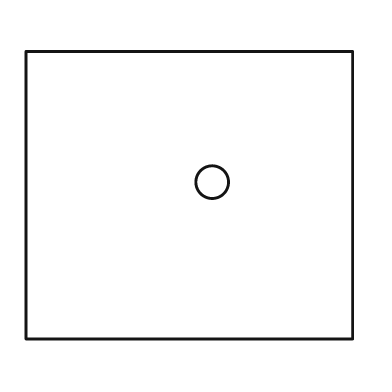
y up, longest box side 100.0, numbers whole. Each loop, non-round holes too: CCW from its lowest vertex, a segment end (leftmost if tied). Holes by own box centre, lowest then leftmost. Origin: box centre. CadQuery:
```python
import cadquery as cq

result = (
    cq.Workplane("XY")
    .moveTo(-50.0, -44.0)
    .lineTo(50.0, -44.0)
    .lineTo(50.0, 44.0)
    .lineTo(-50.0, 44.0)
    .close()
    .moveTo(7.0, 4.0)
    .circle(5.0)
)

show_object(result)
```